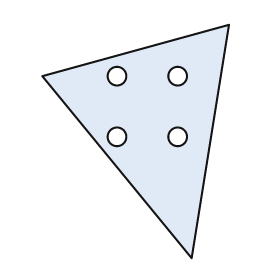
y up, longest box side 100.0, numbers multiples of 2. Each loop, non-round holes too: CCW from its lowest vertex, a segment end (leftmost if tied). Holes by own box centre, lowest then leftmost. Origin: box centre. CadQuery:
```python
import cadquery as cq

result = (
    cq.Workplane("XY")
    .moveTo(24.0, -50.0)
    .lineTo(40.0, 50.0)
    .lineTo(-40.0, 28.0)
    .close()
    .moveTo(-8.0, 2.0)
    .circle(4.0)
    .moveTo(18.0, 2.0)
    .circle(4.0)
    .moveTo(-8.0, 28.0)
    .circle(4.0)
    .moveTo(18.0, 28.0)
    .circle(4.0)
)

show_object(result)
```